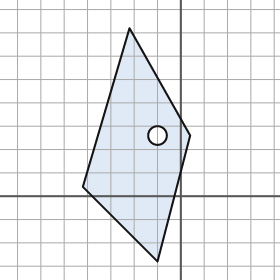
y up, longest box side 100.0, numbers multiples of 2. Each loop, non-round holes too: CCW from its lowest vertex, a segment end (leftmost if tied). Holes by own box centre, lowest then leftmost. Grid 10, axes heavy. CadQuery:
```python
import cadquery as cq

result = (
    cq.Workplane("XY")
    .moveTo(-10.0, -28.0)
    .lineTo(4.0, 26.0)
    .lineTo(-22.0, 72.0)
    .lineTo(-42.0, 4.0)
    .close()
    .moveTo(-10.0, 26.0)
    .circle(4.0)
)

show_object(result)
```